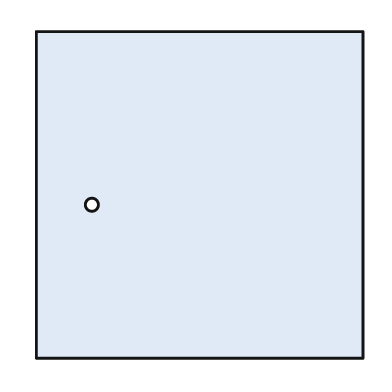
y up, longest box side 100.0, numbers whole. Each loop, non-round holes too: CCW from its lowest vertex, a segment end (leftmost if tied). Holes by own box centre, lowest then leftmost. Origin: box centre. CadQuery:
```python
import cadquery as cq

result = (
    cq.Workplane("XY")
    .moveTo(-50.0, -50.0)
    .lineTo(50.0, -50.0)
    .lineTo(50.0, 50.0)
    .lineTo(-50.0, 50.0)
    .close()
    .moveTo(-33.0, -3.0)
    .circle(2.0)
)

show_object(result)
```